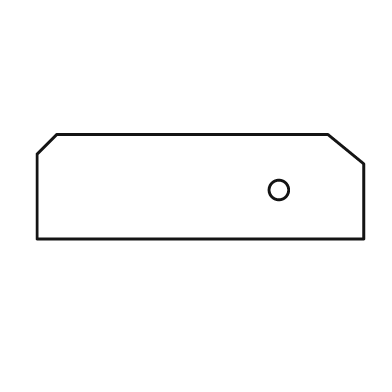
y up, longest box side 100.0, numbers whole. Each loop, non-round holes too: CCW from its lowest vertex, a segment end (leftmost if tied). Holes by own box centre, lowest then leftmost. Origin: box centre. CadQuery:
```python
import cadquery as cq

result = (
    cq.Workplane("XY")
    .moveTo(-50.0, -16.0)
    .lineTo(50.0, -16.0)
    .lineTo(50.0, 7.0)
    .lineTo(39.0, 16.0)
    .lineTo(-44.0, 16.0)
    .lineTo(-50.0, 10.0)
    .close()
    .moveTo(24.0, -1.0)
    .circle(3.0)
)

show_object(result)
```